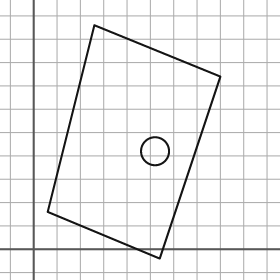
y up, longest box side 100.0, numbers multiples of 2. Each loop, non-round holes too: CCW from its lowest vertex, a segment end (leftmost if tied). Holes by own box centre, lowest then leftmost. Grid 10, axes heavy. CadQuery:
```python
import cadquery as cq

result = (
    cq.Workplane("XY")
    .moveTo(54.0, -4.0)
    .lineTo(80.0, 74.0)
    .lineTo(26.0, 96.0)
    .lineTo(6.0, 16.0)
    .close()
    .moveTo(52.0, 42.0)
    .circle(6.0)
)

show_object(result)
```